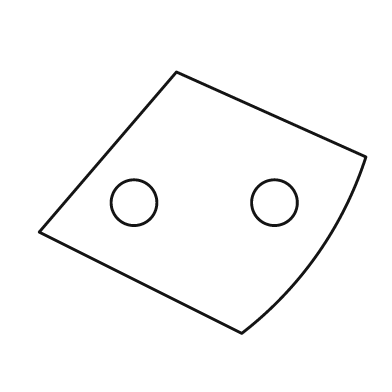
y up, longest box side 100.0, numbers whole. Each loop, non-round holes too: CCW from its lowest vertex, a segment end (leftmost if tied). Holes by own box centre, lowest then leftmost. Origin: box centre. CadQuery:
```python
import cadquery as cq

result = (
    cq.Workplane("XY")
    .moveTo(12.0, -40.0)
    .threePointArc((35.0, -16.0), (50.0, 14.0))
    .lineTo(-8.0, 40.0)
    .lineTo(-50.0, -9.0)
    .close()
    .moveTo(-21.0, 0.0)
    .circle(7.0)
    .moveTo(22.0, 0.0)
    .circle(7.0)
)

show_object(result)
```